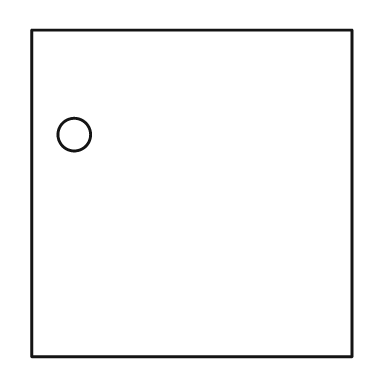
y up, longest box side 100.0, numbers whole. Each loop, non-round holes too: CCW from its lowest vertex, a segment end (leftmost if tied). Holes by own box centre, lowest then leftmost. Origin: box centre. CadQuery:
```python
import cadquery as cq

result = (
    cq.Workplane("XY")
    .moveTo(-49.0, -50.0)
    .lineTo(49.0, -50.0)
    .lineTo(49.0, 50.0)
    .lineTo(-49.0, 50.0)
    .close()
    .moveTo(-36.0, 18.0)
    .circle(5.0)
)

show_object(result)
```